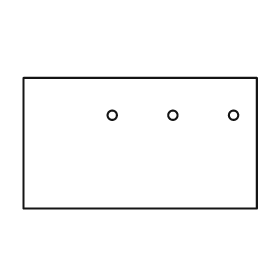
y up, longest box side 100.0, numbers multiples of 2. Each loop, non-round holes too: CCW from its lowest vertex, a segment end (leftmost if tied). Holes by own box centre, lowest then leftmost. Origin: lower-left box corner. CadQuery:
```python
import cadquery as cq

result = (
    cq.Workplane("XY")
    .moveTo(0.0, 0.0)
    .lineTo(100.0, 0.0)
    .lineTo(100.0, 56.0)
    .lineTo(0.0, 56.0)
    .close()
    .moveTo(38.0, 40.0)
    .circle(2.0)
    .moveTo(64.0, 40.0)
    .circle(2.0)
    .moveTo(90.0, 40.0)
    .circle(2.0)
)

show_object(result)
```